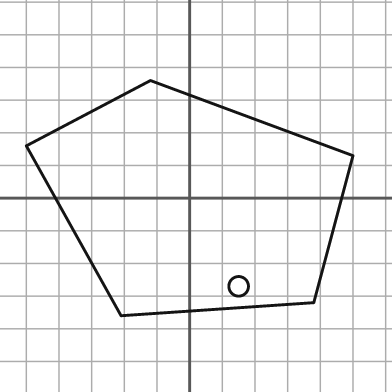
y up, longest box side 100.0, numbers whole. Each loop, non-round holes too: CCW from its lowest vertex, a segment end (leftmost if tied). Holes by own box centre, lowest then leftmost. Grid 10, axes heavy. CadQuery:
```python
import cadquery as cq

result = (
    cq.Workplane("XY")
    .moveTo(-21.0, -36.0)
    .lineTo(38.0, -32.0)
    .lineTo(50.0, 13.0)
    .lineTo(-12.0, 36.0)
    .lineTo(-50.0, 16.0)
    .close()
    .moveTo(15.0, -27.0)
    .circle(3.0)
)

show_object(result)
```